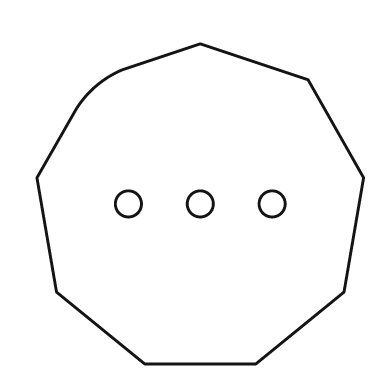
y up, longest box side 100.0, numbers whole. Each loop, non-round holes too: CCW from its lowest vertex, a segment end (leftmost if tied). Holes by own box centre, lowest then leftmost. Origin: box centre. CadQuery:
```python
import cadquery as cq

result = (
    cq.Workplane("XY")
    .moveTo(-17.0, -49.0)
    .lineTo(17.0, -49.0)
    .lineTo(44.0, -27.0)
    .lineTo(50.0, 8.0)
    .lineTo(33.0, 38.0)
    .lineTo(0.0, 49.0)
    .lineTo(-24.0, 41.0)
    .threePointArc((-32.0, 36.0), (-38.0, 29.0))
    .lineTo(-50.0, 8.0)
    .lineTo(-44.0, -27.0)
    .close()
    .moveTo(-22.0, 0.0)
    .circle(4.0)
    .moveTo(0.0, 0.0)
    .circle(4.0)
    .moveTo(22.0, 0.0)
    .circle(4.0)
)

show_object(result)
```